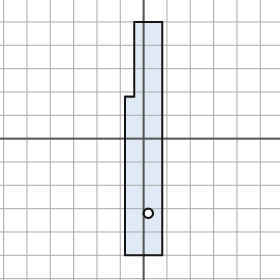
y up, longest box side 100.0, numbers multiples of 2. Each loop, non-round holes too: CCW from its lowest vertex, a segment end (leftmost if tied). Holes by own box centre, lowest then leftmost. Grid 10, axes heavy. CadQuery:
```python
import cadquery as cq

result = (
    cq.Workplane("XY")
    .moveTo(-8.0, -50.0)
    .lineTo(8.0, -50.0)
    .lineTo(8.0, 50.0)
    .lineTo(-4.0, 50.0)
    .lineTo(-4.0, 18.0)
    .lineTo(-8.0, 18.0)
    .close()
    .moveTo(2.0, -32.0)
    .circle(2.0)
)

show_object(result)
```